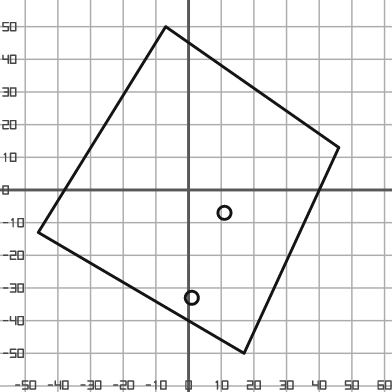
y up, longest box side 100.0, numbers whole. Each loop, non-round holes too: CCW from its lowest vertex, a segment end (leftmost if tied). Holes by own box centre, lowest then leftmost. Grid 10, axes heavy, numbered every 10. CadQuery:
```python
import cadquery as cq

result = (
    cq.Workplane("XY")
    .moveTo(17.0, -50.0)
    .lineTo(46.0, 13.0)
    .lineTo(-7.0, 50.0)
    .lineTo(-46.0, -13.0)
    .close()
    .moveTo(1.0, -33.0)
    .circle(2.0)
    .moveTo(11.0, -7.0)
    .circle(2.0)
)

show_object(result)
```